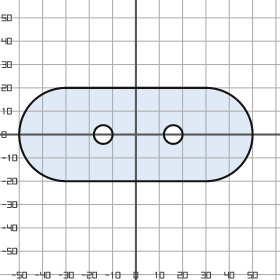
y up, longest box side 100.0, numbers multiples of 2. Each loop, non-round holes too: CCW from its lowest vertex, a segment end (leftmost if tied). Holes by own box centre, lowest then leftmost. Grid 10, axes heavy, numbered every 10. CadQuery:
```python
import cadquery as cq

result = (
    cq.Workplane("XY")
    .moveTo(-30.0, -20.0)
    .lineTo(30.0, -20.0)
    .threePointArc((50.0, 0.0), (30.0, 20.0))
    .lineTo(-30.0, 20.0)
    .threePointArc((-50.0, 0.0), (-30.0, -20.0))
    .close()
    .moveTo(-14.0, 0.0)
    .circle(4.0)
    .moveTo(16.0, 0.0)
    .circle(4.0)
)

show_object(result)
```